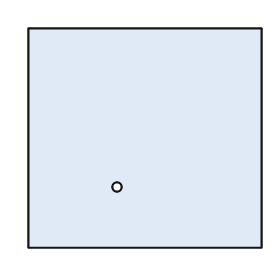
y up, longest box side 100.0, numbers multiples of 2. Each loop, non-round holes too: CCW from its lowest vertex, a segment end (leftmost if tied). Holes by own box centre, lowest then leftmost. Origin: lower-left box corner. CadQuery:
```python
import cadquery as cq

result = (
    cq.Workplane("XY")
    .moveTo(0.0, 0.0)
    .lineTo(100.0, 0.0)
    .lineTo(100.0, 94.0)
    .lineTo(0.0, 94.0)
    .close()
    .moveTo(38.0, 26.0)
    .circle(2.0)
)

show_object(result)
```